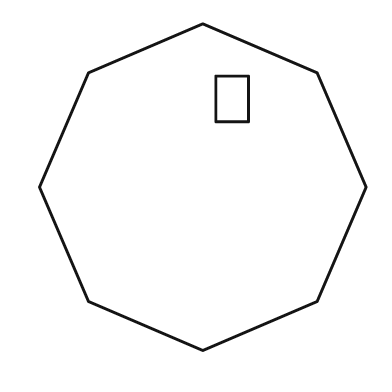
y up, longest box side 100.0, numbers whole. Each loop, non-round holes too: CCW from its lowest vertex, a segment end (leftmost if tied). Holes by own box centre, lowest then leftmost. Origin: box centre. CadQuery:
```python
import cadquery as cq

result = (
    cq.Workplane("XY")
    .moveTo(0.0, -50.0)
    .lineTo(35.0, -35.0)
    .lineTo(50.0, 0.0)
    .lineTo(35.0, 35.0)
    .lineTo(0.0, 50.0)
    .lineTo(-35.0, 35.0)
    .lineTo(-50.0, 0.0)
    .lineTo(-35.0, -35.0)
    .close()
    .moveTo(4.0, 20.0)
    .lineTo(14.0, 20.0)
    .lineTo(14.0, 34.0)
    .lineTo(4.0, 34.0)
    .close()
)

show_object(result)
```